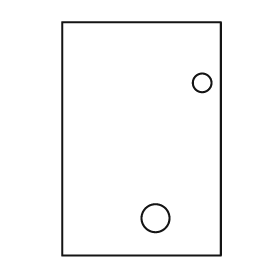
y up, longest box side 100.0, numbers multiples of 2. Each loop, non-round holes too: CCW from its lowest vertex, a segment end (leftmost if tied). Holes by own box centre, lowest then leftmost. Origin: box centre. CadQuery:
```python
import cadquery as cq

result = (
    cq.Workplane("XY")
    .moveTo(-34.0, -50.0)
    .lineTo(34.0, -50.0)
    .lineTo(34.0, 50.0)
    .lineTo(-34.0, 50.0)
    .close()
    .moveTo(6.0, -34.0)
    .circle(6.0)
    .moveTo(26.0, 24.0)
    .circle(4.0)
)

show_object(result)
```